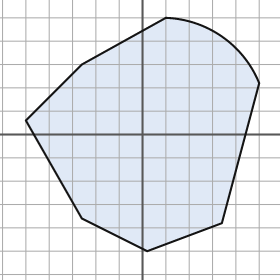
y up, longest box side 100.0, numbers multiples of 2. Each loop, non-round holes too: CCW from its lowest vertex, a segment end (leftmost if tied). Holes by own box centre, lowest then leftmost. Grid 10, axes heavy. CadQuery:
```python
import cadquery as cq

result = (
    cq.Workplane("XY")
    .moveTo(2.0, -50.0)
    .lineTo(34.0, -38.0)
    .lineTo(50.0, 22.0)
    .threePointArc((34.0, 42.0), (10.0, 50.0))
    .lineTo(-26.0, 30.0)
    .lineTo(-50.0, 6.0)
    .lineTo(-26.0, -36.0)
    .close()
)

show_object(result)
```